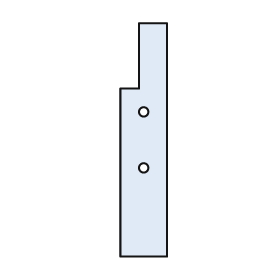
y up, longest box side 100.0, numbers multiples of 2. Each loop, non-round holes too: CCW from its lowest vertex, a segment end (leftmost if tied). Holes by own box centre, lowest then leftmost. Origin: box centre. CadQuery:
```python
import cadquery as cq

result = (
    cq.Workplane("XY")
    .moveTo(-10.0, -50.0)
    .lineTo(10.0, -50.0)
    .lineTo(10.0, 50.0)
    .lineTo(-2.0, 50.0)
    .lineTo(-2.0, 22.0)
    .lineTo(-10.0, 22.0)
    .close()
    .moveTo(0.0, -12.0)
    .circle(2.0)
    .moveTo(0.0, 12.0)
    .circle(2.0)
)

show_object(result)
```